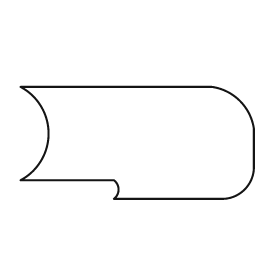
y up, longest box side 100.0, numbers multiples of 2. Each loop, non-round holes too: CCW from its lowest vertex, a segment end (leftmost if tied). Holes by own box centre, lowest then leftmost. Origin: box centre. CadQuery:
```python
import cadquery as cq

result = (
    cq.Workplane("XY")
    .moveTo(-10.0, -24.0)
    .lineTo(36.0, -24.0)
    .threePointArc((46.0, -20.0), (50.0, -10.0))
    .lineTo(50.0, 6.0)
    .threePointArc((44.0, 18.0), (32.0, 24.0))
    .lineTo(-50.0, 24.0)
    .threePointArc((-38.0, 4.0), (-50.0, -16.0))
    .lineTo(-10.0, -16.0)
    .threePointArc((-8.0, -20.0), (-10.0, -24.0))
    .close()
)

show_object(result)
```